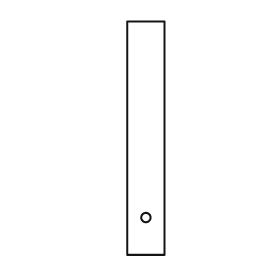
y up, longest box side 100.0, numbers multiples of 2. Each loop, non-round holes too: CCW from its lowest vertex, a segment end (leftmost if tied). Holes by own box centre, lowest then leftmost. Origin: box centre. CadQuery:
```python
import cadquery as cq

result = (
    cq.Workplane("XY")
    .moveTo(-8.0, -50.0)
    .lineTo(8.0, -50.0)
    .lineTo(8.0, 50.0)
    .lineTo(-8.0, 50.0)
    .close()
    .moveTo(0.0, -34.0)
    .circle(2.0)
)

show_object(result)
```